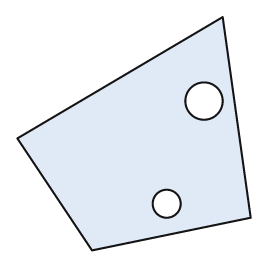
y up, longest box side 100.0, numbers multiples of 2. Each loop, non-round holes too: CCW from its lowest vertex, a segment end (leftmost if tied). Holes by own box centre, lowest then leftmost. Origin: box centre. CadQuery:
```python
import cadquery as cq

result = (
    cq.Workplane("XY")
    .moveTo(-18.0, -50.0)
    .lineTo(50.0, -36.0)
    .lineTo(38.0, 50.0)
    .lineTo(-50.0, -2.0)
    .close()
    .moveTo(14.0, -30.0)
    .circle(6.0)
    .moveTo(30.0, 14.0)
    .circle(8.0)
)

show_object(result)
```